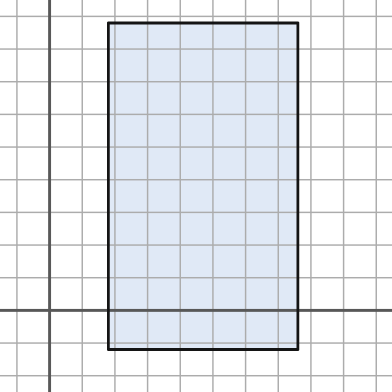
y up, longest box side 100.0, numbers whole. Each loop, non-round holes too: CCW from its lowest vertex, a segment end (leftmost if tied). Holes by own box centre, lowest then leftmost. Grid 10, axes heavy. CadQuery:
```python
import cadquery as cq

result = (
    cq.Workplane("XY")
    .moveTo(18.0, -12.0)
    .lineTo(76.0, -12.0)
    .lineTo(76.0, 88.0)
    .lineTo(18.0, 88.0)
    .close()
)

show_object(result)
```